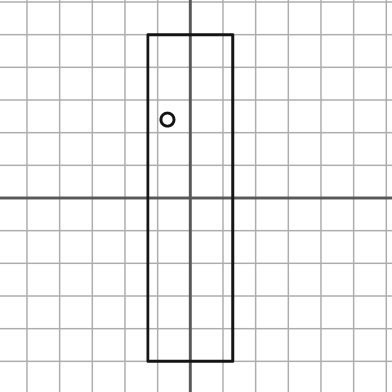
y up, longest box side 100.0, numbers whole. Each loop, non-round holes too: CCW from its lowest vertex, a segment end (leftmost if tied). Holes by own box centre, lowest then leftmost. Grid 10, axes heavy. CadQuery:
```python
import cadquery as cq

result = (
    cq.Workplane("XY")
    .moveTo(-13.0, -50.0)
    .lineTo(13.0, -50.0)
    .lineTo(13.0, 50.0)
    .lineTo(-13.0, 50.0)
    .close()
    .moveTo(-7.0, 24.0)
    .circle(2.0)
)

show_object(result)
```